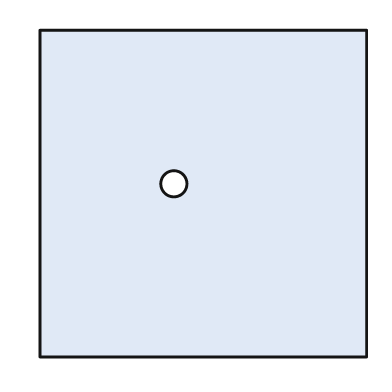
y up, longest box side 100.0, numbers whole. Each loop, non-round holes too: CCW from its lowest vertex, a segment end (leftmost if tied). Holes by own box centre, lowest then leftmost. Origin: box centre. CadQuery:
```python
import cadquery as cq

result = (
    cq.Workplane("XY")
    .moveTo(-50.0, -50.0)
    .lineTo(50.0, -50.0)
    .lineTo(50.0, 50.0)
    .lineTo(-50.0, 50.0)
    .close()
    .moveTo(-9.0, 3.0)
    .circle(4.0)
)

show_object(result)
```